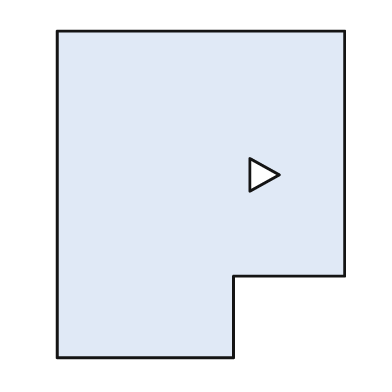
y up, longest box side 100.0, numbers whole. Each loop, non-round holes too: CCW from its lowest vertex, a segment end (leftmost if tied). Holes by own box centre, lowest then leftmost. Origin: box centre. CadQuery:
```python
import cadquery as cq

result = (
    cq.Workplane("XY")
    .moveTo(-44.0, -50.0)
    .lineTo(10.0, -50.0)
    .lineTo(10.0, -25.0)
    .lineTo(44.0, -25.0)
    .lineTo(44.0, 50.0)
    .lineTo(-44.0, 50.0)
    .close()
    .moveTo(15.0, 1.0)
    .lineTo(24.0, 6.0)
    .lineTo(15.0, 11.0)
    .close()
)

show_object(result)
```